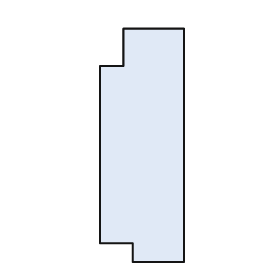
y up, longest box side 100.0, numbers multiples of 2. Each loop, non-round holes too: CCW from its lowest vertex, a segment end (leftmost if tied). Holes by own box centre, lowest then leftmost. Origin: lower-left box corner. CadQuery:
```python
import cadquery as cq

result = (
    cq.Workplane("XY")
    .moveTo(14.0, 0.0)
    .lineTo(36.0, 0.0)
    .lineTo(36.0, 100.0)
    .lineTo(10.0, 100.0)
    .lineTo(10.0, 84.0)
    .lineTo(0.0, 84.0)
    .lineTo(0.0, 8.0)
    .lineTo(14.0, 8.0)
    .close()
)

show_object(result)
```